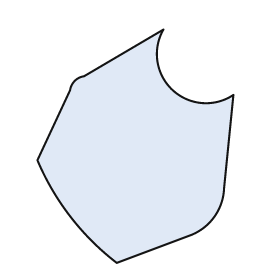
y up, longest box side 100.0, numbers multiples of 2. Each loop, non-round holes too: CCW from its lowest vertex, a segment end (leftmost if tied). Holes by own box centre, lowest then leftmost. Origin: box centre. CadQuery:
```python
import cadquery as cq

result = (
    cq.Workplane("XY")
    .moveTo(-8.0, -50.0)
    .lineTo(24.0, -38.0)
    .threePointArc((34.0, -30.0), (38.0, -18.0))
    .lineTo(42.0, 22.0)
    .threePointArc((16.0, 24.0), (12.0, 50.0))
    .lineTo(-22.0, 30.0)
    .threePointArc((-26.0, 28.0), (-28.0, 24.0))
    .lineTo(-42.0, -6.0)
    .threePointArc((-28.0, -30.0), (-8.0, -50.0))
    .close()
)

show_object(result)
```